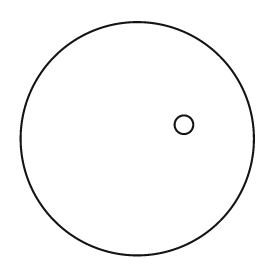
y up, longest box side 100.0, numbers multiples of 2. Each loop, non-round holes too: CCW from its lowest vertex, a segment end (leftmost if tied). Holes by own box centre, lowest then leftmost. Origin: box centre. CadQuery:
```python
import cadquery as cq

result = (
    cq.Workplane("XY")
    .moveTo(0.0, 0.0)
    .circle(50.0)
    .moveTo(20.0, 6.0)
    .circle(4.0)
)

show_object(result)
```